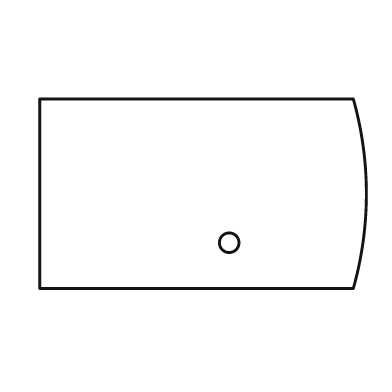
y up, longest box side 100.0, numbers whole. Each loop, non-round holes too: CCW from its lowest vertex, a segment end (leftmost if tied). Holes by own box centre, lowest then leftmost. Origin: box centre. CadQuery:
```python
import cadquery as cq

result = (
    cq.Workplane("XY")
    .moveTo(-50.0, -29.0)
    .lineTo(46.0, -29.0)
    .threePointArc((50.0, 0.0), (46.0, 29.0))
    .lineTo(-50.0, 29.0)
    .close()
    .moveTo(8.0, -15.0)
    .circle(3.0)
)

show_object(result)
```